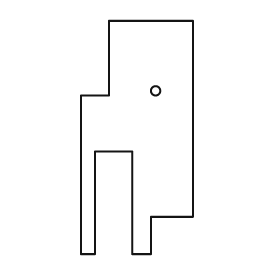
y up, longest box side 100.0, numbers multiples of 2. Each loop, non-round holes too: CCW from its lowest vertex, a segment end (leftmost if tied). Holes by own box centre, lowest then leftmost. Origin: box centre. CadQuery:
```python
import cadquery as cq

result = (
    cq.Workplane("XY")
    .moveTo(-24.0, -50.0)
    .lineTo(-18.0, -50.0)
    .lineTo(-18.0, -6.0)
    .lineTo(-2.0, -6.0)
    .lineTo(-2.0, -50.0)
    .lineTo(6.0, -50.0)
    .lineTo(6.0, -34.0)
    .lineTo(24.0, -34.0)
    .lineTo(24.0, 50.0)
    .lineTo(-12.0, 50.0)
    .lineTo(-12.0, 18.0)
    .lineTo(-24.0, 18.0)
    .close()
    .moveTo(8.0, 20.0)
    .circle(2.0)
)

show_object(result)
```